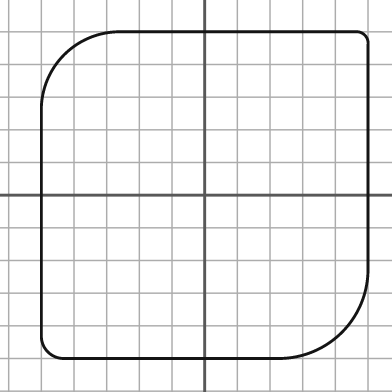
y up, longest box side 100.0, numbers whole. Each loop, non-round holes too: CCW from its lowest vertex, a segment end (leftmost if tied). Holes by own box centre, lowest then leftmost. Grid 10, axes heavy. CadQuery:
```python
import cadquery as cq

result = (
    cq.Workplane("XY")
    .moveTo(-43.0, -50.0)
    .lineTo(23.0, -50.0)
    .threePointArc((42.0, -42.0), (50.0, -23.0))
    .lineTo(50.0, 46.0)
    .threePointArc((49.0, 49.0), (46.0, 50.0))
    .lineTo(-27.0, 50.0)
    .threePointArc((-43.0, 43.0), (-50.0, 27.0))
    .lineTo(-50.0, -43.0)
    .threePointArc((-48.0, -48.0), (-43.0, -50.0))
    .close()
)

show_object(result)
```